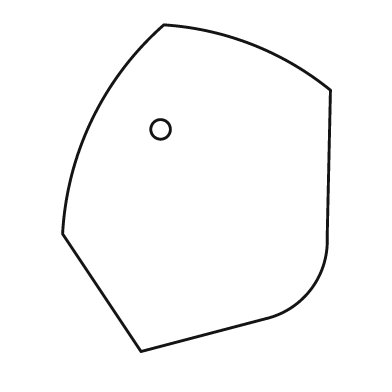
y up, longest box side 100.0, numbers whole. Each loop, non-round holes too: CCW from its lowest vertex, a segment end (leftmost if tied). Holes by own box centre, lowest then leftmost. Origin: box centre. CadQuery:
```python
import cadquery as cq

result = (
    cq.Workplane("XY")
    .moveTo(-17.0, -50.0)
    .lineTo(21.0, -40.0)
    .threePointArc((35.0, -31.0), (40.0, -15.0))
    .lineTo(41.0, 30.0)
    .threePointArc((17.0, 44.0), (-10.0, 50.0))
    .threePointArc((-32.0, 21.0), (-41.0, -14.0))
    .close()
    .moveTo(-11.0, 18.0)
    .circle(3.0)
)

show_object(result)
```